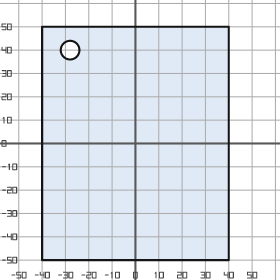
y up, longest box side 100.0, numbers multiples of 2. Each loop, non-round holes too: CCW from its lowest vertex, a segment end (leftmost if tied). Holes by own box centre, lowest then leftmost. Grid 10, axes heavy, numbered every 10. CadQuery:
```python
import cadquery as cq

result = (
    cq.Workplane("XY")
    .moveTo(-40.0, -50.0)
    .lineTo(40.0, -50.0)
    .lineTo(40.0, 50.0)
    .lineTo(-40.0, 50.0)
    .close()
    .moveTo(-28.0, 40.0)
    .circle(4.0)
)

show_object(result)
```